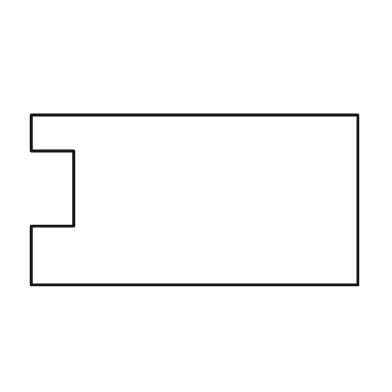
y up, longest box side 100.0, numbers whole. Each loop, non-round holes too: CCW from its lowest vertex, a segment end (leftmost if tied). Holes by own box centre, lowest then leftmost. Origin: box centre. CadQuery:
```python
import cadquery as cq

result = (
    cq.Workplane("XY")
    .moveTo(-50.0, -26.0)
    .lineTo(50.0, -26.0)
    .lineTo(50.0, 26.0)
    .lineTo(-50.0, 26.0)
    .lineTo(-50.0, 15.0)
    .lineTo(-37.0, 15.0)
    .lineTo(-37.0, -8.0)
    .lineTo(-50.0, -8.0)
    .close()
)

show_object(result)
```